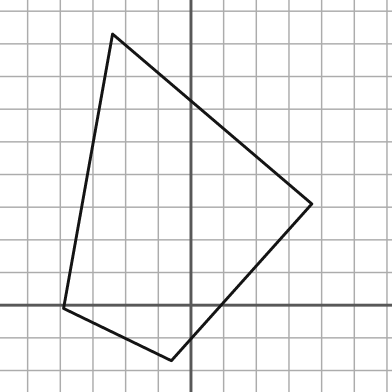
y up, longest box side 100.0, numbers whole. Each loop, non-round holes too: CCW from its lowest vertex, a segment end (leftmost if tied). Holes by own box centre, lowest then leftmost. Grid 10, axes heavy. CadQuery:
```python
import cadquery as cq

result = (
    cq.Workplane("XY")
    .moveTo(-6.0, -17.0)
    .lineTo(37.0, 31.0)
    .lineTo(-24.0, 83.0)
    .lineTo(-39.0, -1.0)
    .close()
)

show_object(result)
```